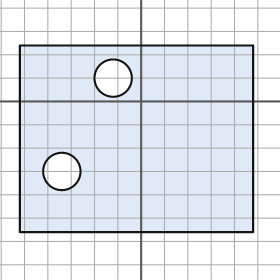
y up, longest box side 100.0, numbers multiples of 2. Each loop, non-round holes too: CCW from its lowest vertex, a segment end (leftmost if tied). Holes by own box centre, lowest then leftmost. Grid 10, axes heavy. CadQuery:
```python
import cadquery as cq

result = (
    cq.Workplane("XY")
    .moveTo(-52.0, -56.0)
    .lineTo(48.0, -56.0)
    .lineTo(48.0, 24.0)
    .lineTo(-52.0, 24.0)
    .close()
    .moveTo(-34.0, -30.0)
    .circle(8.0)
    .moveTo(-12.0, 10.0)
    .circle(8.0)
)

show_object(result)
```